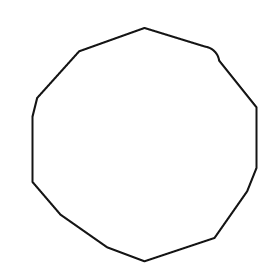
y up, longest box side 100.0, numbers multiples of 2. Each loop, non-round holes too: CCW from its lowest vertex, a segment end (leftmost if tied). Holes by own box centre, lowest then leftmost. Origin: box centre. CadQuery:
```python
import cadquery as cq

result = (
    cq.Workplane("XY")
    .moveTo(0.0, -50.0)
    .lineTo(30.0, -40.0)
    .lineTo(44.0, -20.0)
    .lineTo(48.0, -10.0)
    .lineTo(48.0, 16.0)
    .lineTo(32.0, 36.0)
    .threePointArc((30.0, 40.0), (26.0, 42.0))
    .lineTo(0.0, 50.0)
    .lineTo(-28.0, 40.0)
    .lineTo(-46.0, 20.0)
    .lineTo(-48.0, 12.0)
    .lineTo(-48.0, -16.0)
    .lineTo(-36.0, -30.0)
    .lineTo(-16.0, -44.0)
    .close()
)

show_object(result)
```